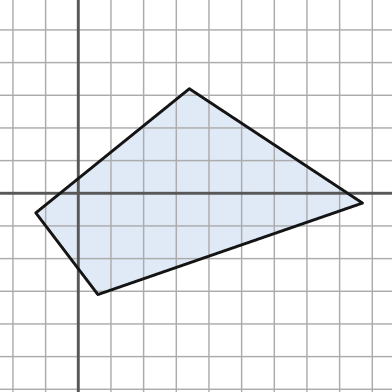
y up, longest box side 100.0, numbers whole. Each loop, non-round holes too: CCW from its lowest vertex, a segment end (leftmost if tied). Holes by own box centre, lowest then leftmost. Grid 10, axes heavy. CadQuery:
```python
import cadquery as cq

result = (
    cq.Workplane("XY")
    .moveTo(6.0, -31.0)
    .lineTo(87.0, -3.0)
    .lineTo(34.0, 32.0)
    .lineTo(-13.0, -6.0)
    .close()
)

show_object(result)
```